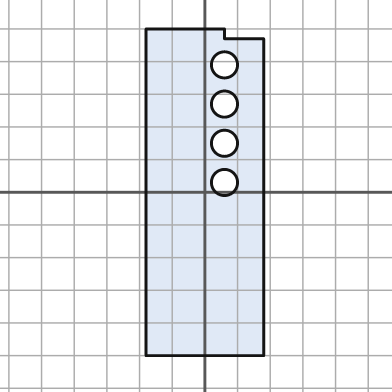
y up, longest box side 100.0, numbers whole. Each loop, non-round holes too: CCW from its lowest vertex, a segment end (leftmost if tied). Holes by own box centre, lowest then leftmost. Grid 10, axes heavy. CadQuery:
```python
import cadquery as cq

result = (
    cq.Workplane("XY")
    .moveTo(-18.0, -50.0)
    .lineTo(18.0, -50.0)
    .lineTo(18.0, 47.0)
    .lineTo(6.0, 47.0)
    .lineTo(6.0, 50.0)
    .lineTo(-18.0, 50.0)
    .close()
    .moveTo(6.0, 3.0)
    .circle(4.0)
    .moveTo(6.0, 15.0)
    .circle(4.0)
    .moveTo(6.0, 27.0)
    .circle(4.0)
    .moveTo(6.0, 39.0)
    .circle(4.0)
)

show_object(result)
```